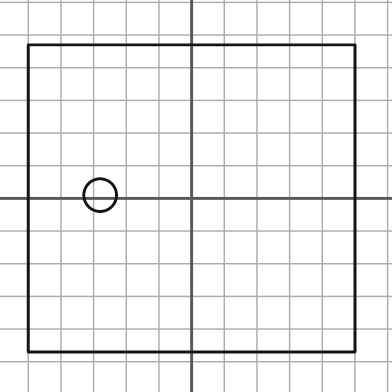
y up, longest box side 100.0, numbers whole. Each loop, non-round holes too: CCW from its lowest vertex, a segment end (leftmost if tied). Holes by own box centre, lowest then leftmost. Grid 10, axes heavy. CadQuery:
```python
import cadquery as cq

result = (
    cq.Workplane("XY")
    .moveTo(-50.0, -47.0)
    .lineTo(50.0, -47.0)
    .lineTo(50.0, 47.0)
    .lineTo(-50.0, 47.0)
    .close()
    .moveTo(-28.0, 1.0)
    .circle(5.0)
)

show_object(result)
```